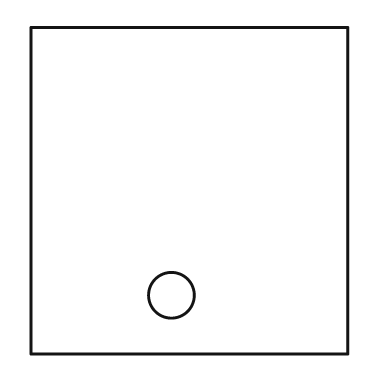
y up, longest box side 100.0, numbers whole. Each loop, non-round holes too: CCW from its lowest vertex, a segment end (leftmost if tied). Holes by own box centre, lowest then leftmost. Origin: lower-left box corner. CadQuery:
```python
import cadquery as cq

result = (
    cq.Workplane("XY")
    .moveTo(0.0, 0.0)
    .lineTo(97.0, 0.0)
    .lineTo(97.0, 100.0)
    .lineTo(0.0, 100.0)
    .close()
    .moveTo(43.0, 18.0)
    .circle(7.0)
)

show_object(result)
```